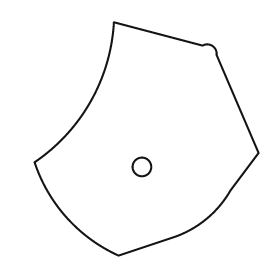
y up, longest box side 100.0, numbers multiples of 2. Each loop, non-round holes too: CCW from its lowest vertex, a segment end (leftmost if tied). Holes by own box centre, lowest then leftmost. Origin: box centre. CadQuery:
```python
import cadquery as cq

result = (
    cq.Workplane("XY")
    .moveTo(-12.0, -50.0)
    .lineTo(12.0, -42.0)
    .threePointArc((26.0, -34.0), (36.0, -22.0))
    .lineTo(48.0, -6.0)
    .lineTo(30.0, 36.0)
    .threePointArc((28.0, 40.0), (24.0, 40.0))
    .lineTo(-14.0, 50.0)
    .threePointArc((-24.0, 16.0), (-48.0, -10.0))
    .threePointArc((-34.0, -34.0), (-12.0, -50.0))
    .close()
    .moveTo(-2.0, -12.0)
    .circle(4.0)
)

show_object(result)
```